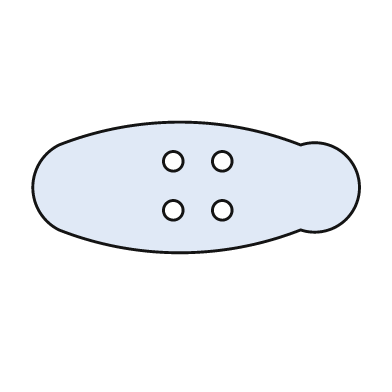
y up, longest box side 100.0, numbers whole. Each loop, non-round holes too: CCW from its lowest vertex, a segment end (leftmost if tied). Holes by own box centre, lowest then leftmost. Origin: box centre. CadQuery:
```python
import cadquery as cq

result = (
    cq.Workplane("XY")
    .moveTo(-42.0, -13.0)
    .threePointArc((-5.0, -20.0), (32.0, -13.0))
    .threePointArc((50.0, 0.0), (32.0, 13.0))
    .threePointArc((-5.0, 20.0), (-42.0, 13.0))
    .threePointArc((-50.0, 0.0), (-42.0, -13.0))
    .close()
    .moveTo(-7.0, -7.0)
    .circle(3.0)
    .moveTo(8.0, -7.0)
    .circle(3.0)
    .moveTo(-7.0, 8.0)
    .circle(3.0)
    .moveTo(8.0, 8.0)
    .circle(3.0)
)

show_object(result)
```